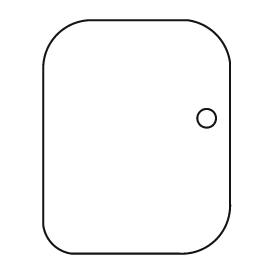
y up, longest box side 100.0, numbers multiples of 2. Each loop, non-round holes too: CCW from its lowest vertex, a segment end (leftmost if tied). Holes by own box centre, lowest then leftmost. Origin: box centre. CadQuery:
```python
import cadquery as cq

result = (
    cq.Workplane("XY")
    .moveTo(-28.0, -50.0)
    .lineTo(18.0, -50.0)
    .threePointArc((34.0, -44.0), (40.0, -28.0))
    .lineTo(40.0, 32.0)
    .threePointArc((34.0, 44.0), (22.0, 50.0))
    .lineTo(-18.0, 50.0)
    .threePointArc((-34.0, 44.0), (-40.0, 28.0))
    .lineTo(-40.0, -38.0)
    .threePointArc((-36.0, -46.0), (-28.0, -50.0))
    .close()
    .moveTo(30.0, 8.0)
    .circle(4.0)
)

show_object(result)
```